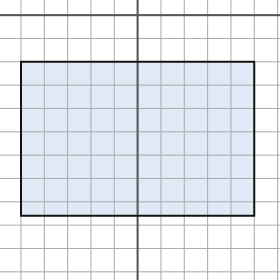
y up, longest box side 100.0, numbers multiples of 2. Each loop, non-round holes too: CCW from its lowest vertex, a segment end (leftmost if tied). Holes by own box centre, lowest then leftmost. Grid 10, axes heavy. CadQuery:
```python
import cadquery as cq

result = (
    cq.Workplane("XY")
    .moveTo(-50.0, -86.0)
    .lineTo(50.0, -86.0)
    .lineTo(50.0, -20.0)
    .lineTo(-50.0, -20.0)
    .close()
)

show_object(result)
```